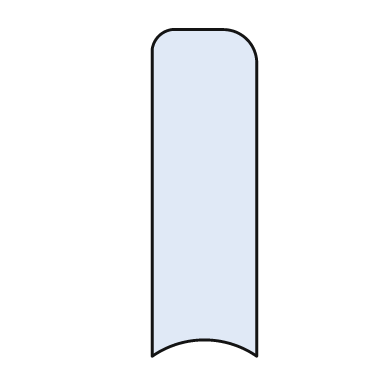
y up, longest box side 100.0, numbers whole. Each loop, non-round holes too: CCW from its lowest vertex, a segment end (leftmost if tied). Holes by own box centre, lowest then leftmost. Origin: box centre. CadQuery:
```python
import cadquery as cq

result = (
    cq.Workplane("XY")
    .moveTo(-16.0, -50.0)
    .threePointArc((0.0, -45.0), (16.0, -50.0))
    .lineTo(16.0, 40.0)
    .threePointArc((13.0, 47.0), (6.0, 50.0))
    .lineTo(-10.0, 50.0)
    .threePointArc((-14.0, 48.0), (-16.0, 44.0))
    .close()
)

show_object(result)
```